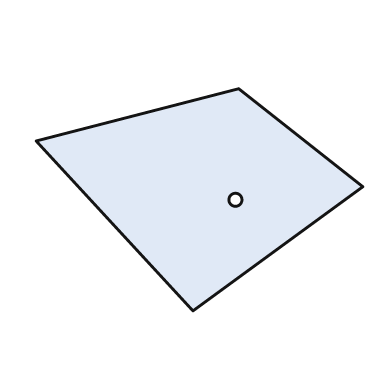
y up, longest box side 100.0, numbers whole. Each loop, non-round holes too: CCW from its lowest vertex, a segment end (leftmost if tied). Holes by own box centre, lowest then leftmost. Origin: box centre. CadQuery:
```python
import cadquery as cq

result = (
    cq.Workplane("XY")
    .moveTo(-2.0, -34.0)
    .lineTo(50.0, 4.0)
    .lineTo(12.0, 34.0)
    .lineTo(-50.0, 18.0)
    .close()
    .moveTo(11.0, 0.0)
    .circle(2.0)
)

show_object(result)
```